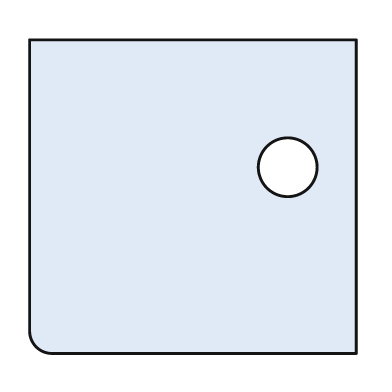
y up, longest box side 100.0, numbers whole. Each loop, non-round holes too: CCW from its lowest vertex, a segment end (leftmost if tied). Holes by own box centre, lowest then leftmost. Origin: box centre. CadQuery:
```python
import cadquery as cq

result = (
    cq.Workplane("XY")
    .moveTo(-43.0, -48.0)
    .lineTo(50.0, -48.0)
    .lineTo(50.0, 48.0)
    .lineTo(-50.0, 48.0)
    .lineTo(-50.0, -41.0)
    .threePointArc((-48.0, -46.0), (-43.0, -48.0))
    .close()
    .moveTo(29.0, 9.0)
    .circle(9.0)
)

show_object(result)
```